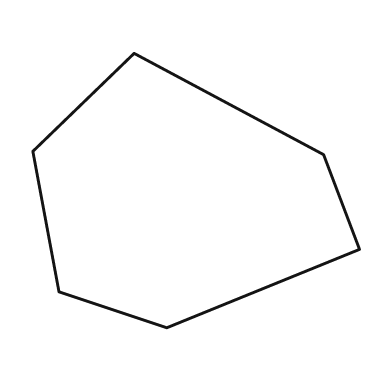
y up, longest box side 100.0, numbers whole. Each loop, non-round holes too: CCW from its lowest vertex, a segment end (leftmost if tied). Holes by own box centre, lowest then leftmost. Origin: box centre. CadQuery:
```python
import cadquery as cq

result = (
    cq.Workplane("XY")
    .moveTo(-9.0, -42.0)
    .lineTo(50.0, -18.0)
    .lineTo(39.0, 11.0)
    .lineTo(-19.0, 42.0)
    .lineTo(-50.0, 12.0)
    .lineTo(-42.0, -31.0)
    .close()
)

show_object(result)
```